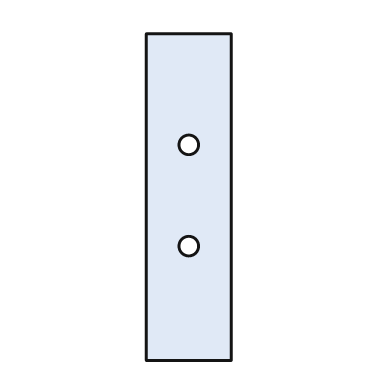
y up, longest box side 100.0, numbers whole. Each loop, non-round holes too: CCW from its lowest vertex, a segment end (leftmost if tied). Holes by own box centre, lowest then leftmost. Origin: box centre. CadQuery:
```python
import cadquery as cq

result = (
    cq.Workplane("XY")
    .moveTo(-13.0, -50.0)
    .lineTo(13.0, -50.0)
    .lineTo(13.0, 50.0)
    .lineTo(-13.0, 50.0)
    .close()
    .moveTo(0.0, -15.0)
    .circle(3.0)
    .moveTo(0.0, 16.0)
    .circle(3.0)
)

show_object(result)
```